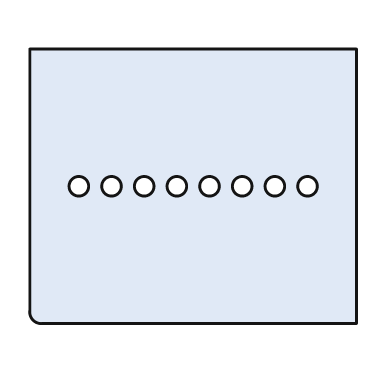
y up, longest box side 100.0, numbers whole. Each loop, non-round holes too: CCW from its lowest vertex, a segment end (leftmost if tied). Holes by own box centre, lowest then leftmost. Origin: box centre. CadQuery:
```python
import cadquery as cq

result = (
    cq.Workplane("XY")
    .moveTo(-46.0, -42.0)
    .lineTo(50.0, -42.0)
    .lineTo(50.0, 42.0)
    .lineTo(-50.0, 42.0)
    .lineTo(-50.0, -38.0)
    .threePointArc((-49.0, -41.0), (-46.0, -42.0))
    .close()
    .moveTo(-35.0, 0.0)
    .circle(3.0)
    .moveTo(-25.0, 0.0)
    .circle(3.0)
    .moveTo(-15.0, 0.0)
    .circle(3.0)
    .moveTo(-5.0, 0.0)
    .circle(3.0)
    .moveTo(5.0, 0.0)
    .circle(3.0)
    .moveTo(15.0, 0.0)
    .circle(3.0)
    .moveTo(25.0, 0.0)
    .circle(3.0)
    .moveTo(35.0, 0.0)
    .circle(3.0)
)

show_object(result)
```